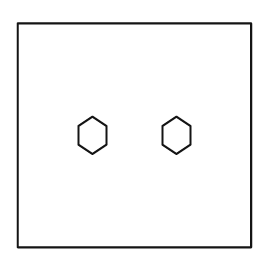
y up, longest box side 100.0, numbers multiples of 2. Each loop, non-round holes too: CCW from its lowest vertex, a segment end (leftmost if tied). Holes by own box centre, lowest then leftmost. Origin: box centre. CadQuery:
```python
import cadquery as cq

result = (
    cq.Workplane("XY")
    .moveTo(-50.0, -48.0)
    .lineTo(50.0, -48.0)
    .lineTo(50.0, 48.0)
    .lineTo(-50.0, 48.0)
    .close()
    .moveTo(-18.0, -8.0)
    .lineTo(-12.0, -4.0)
    .lineTo(-12.0, 4.0)
    .lineTo(-18.0, 8.0)
    .lineTo(-24.0, 4.0)
    .lineTo(-24.0, -4.0)
    .close()
    .moveTo(18.0, -8.0)
    .lineTo(24.0, -4.0)
    .lineTo(24.0, 4.0)
    .lineTo(18.0, 8.0)
    .lineTo(12.0, 4.0)
    .lineTo(12.0, -4.0)
    .close()
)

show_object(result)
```